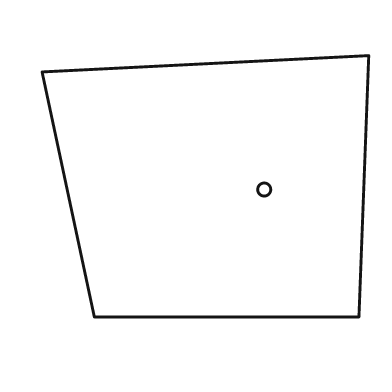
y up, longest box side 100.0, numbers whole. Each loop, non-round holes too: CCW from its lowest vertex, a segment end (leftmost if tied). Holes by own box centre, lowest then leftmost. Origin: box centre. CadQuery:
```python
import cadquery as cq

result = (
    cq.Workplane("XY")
    .moveTo(-34.0, -40.0)
    .lineTo(47.0, -40.0)
    .lineTo(50.0, 40.0)
    .lineTo(-50.0, 35.0)
    .close()
    .moveTo(18.0, -1.0)
    .circle(2.0)
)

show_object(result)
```